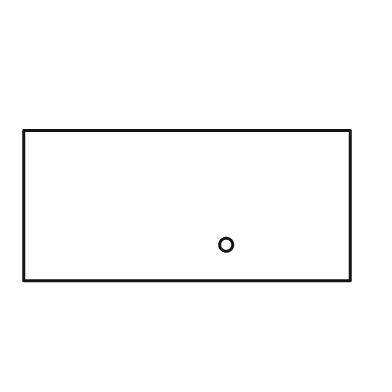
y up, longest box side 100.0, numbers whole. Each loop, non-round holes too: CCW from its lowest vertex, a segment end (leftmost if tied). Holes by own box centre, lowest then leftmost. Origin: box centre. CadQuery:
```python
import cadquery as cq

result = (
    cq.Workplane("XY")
    .moveTo(-50.0, -23.0)
    .lineTo(50.0, -23.0)
    .lineTo(50.0, 23.0)
    .lineTo(-50.0, 23.0)
    .close()
    .moveTo(12.0, -12.0)
    .circle(2.0)
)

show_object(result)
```